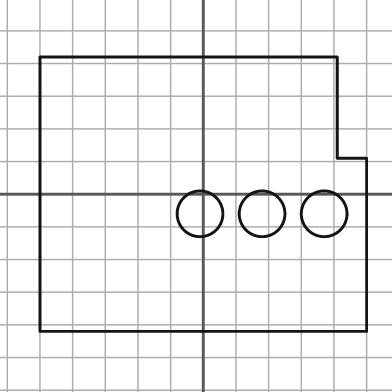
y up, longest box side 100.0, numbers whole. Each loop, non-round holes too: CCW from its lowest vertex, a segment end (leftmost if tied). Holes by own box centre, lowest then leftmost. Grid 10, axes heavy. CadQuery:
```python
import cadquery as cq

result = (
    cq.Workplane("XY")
    .moveTo(-50.0, -42.0)
    .lineTo(50.0, -42.0)
    .lineTo(50.0, 11.0)
    .lineTo(41.0, 11.0)
    .lineTo(41.0, 42.0)
    .lineTo(-50.0, 42.0)
    .close()
    .moveTo(-1.0, -6.0)
    .circle(7.0)
    .moveTo(18.0, -6.0)
    .circle(7.0)
    .moveTo(37.0, -6.0)
    .circle(7.0)
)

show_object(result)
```